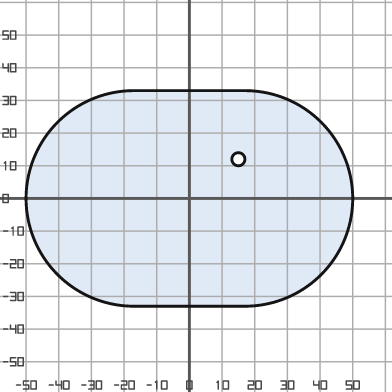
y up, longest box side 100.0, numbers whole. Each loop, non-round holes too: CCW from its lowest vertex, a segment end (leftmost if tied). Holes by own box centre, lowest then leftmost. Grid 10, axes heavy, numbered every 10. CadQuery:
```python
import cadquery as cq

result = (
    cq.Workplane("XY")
    .moveTo(-17.0, -33.0)
    .lineTo(17.0, -33.0)
    .threePointArc((50.0, 0.0), (17.0, 33.0))
    .lineTo(-17.0, 33.0)
    .threePointArc((-50.0, 0.0), (-17.0, -33.0))
    .close()
    .moveTo(15.0, 12.0)
    .circle(2.0)
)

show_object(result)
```